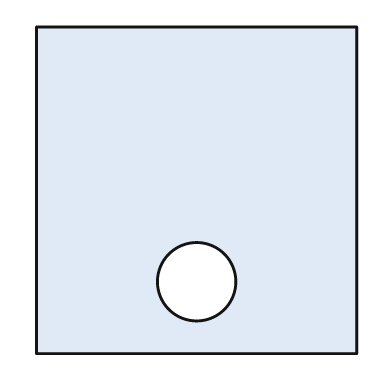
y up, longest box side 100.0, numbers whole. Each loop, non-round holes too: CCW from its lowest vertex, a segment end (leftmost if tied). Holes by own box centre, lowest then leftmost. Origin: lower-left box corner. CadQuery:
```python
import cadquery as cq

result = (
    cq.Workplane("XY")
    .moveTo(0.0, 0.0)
    .lineTo(98.0, 0.0)
    .lineTo(98.0, 100.0)
    .lineTo(0.0, 100.0)
    .close()
    .moveTo(49.0, 22.0)
    .circle(12.0)
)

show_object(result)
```